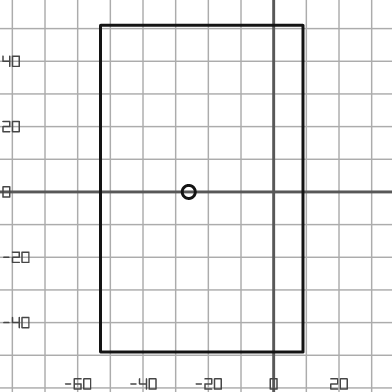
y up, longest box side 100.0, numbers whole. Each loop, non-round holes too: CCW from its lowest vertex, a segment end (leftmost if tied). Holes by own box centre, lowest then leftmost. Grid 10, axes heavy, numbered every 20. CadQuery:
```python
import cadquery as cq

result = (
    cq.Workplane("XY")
    .moveTo(-53.0, -49.0)
    .lineTo(9.0, -49.0)
    .lineTo(9.0, 51.0)
    .lineTo(-53.0, 51.0)
    .close()
    .moveTo(-26.0, 0.0)
    .circle(2.0)
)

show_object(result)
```